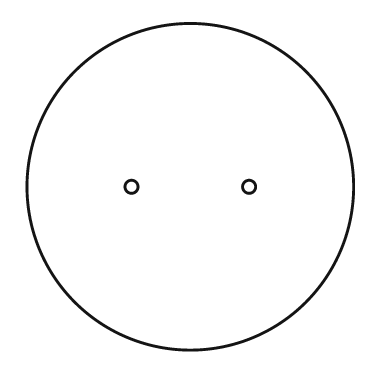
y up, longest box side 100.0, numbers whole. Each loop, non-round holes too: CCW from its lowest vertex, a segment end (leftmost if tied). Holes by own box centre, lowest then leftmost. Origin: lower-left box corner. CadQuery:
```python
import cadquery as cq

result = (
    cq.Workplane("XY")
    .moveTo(50.0, 50.0)
    .circle(50.0)
    .moveTo(32.0, 50.0)
    .circle(2.0)
    .moveTo(68.0, 50.0)
    .circle(2.0)
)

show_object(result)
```